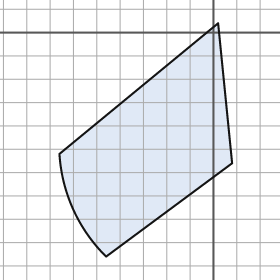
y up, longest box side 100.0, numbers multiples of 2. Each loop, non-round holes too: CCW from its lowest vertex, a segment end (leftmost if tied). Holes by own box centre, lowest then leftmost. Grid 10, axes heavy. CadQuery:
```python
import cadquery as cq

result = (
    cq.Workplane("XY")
    .moveTo(-46.0, -96.0)
    .lineTo(8.0, -56.0)
    .lineTo(2.0, 4.0)
    .lineTo(-66.0, -52.0)
    .threePointArc((-60.0, -76.0), (-46.0, -96.0))
    .close()
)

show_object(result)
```